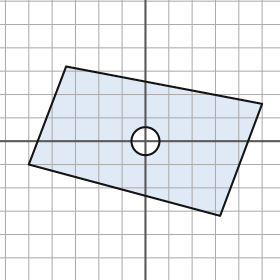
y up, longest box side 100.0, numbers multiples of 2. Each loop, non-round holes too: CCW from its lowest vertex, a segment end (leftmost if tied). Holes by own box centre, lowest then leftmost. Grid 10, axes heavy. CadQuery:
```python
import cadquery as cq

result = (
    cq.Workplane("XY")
    .moveTo(32.0, -32.0)
    .lineTo(50.0, 16.0)
    .lineTo(-34.0, 32.0)
    .lineTo(-50.0, -10.0)
    .close()
    .moveTo(0.0, 0.0)
    .circle(6.0)
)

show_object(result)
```